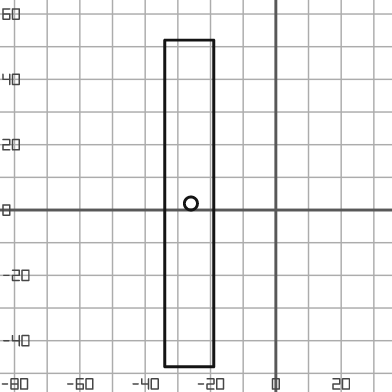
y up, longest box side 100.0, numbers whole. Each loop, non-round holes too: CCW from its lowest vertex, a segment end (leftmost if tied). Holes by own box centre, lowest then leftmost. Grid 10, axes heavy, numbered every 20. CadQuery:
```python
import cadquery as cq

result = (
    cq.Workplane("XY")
    .moveTo(-34.0, -48.0)
    .lineTo(-19.0, -48.0)
    .lineTo(-19.0, 52.0)
    .lineTo(-34.0, 52.0)
    .close()
    .moveTo(-26.0, 2.0)
    .circle(2.0)
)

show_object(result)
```